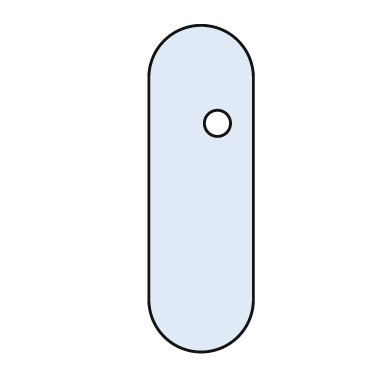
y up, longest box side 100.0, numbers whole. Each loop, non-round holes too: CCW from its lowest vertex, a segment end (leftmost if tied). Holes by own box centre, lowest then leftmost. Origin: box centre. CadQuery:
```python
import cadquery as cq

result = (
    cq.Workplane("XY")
    .moveTo(-16.0, -34.0)
    .threePointArc((0.0, -50.0), (16.0, -34.0))
    .lineTo(16.0, 34.0)
    .threePointArc((0.0, 50.0), (-16.0, 34.0))
    .close()
    .moveTo(5.0, 20.0)
    .circle(4.0)
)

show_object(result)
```